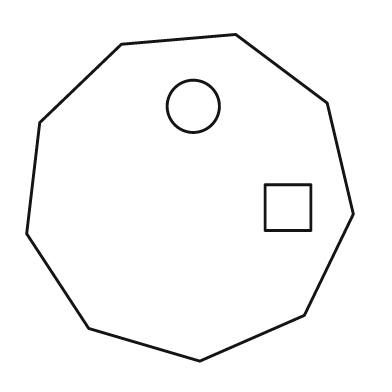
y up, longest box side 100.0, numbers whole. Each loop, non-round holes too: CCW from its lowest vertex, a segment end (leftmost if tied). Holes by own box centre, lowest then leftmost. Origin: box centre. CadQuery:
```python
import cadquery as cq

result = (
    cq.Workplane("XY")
    .moveTo(3.0, -50.0)
    .lineTo(35.0, -36.0)
    .lineTo(50.0, -5.0)
    .lineTo(42.0, 29.0)
    .lineTo(14.0, 50.0)
    .lineTo(-21.0, 47.0)
    .lineTo(-46.0, 23.0)
    .lineTo(-50.0, -11.0)
    .lineTo(-31.0, -40.0)
    .close()
    .moveTo(23.0, -10.0)
    .lineTo(37.0, -10.0)
    .lineTo(37.0, 4.0)
    .lineTo(23.0, 4.0)
    .close()
    .moveTo(1.0, 28.0)
    .circle(8.0)
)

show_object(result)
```